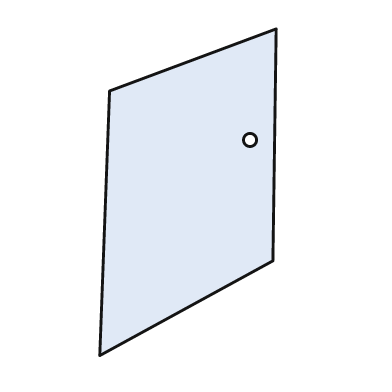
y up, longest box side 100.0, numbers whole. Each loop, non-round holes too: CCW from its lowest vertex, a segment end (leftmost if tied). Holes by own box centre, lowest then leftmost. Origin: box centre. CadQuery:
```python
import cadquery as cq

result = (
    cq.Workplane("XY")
    .moveTo(-27.0, -50.0)
    .lineTo(26.0, -21.0)
    .lineTo(27.0, 50.0)
    .lineTo(-24.0, 31.0)
    .close()
    .moveTo(19.0, 16.0)
    .circle(2.0)
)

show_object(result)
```